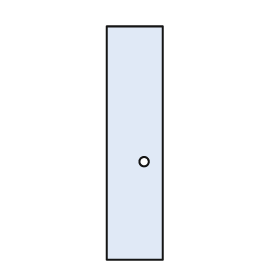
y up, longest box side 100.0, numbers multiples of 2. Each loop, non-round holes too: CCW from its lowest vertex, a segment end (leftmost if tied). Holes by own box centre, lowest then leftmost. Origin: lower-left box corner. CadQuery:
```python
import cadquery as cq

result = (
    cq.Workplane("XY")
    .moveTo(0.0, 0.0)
    .lineTo(24.0, 0.0)
    .lineTo(24.0, 100.0)
    .lineTo(0.0, 100.0)
    .close()
    .moveTo(16.0, 42.0)
    .circle(2.0)
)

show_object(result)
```